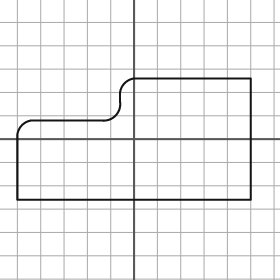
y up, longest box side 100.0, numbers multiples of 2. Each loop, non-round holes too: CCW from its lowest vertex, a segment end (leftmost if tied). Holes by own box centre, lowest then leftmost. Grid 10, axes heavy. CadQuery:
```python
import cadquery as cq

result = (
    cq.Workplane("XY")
    .moveTo(-50.0, -26.0)
    .lineTo(50.0, -26.0)
    .lineTo(50.0, 26.0)
    .lineTo(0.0, 26.0)
    .threePointArc((-4.0, 24.0), (-6.0, 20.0))
    .lineTo(-6.0, 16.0)
    .threePointArc((-8.0, 10.0), (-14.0, 8.0))
    .lineTo(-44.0, 8.0)
    .threePointArc((-48.0, 6.0), (-50.0, 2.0))
    .close()
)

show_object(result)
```